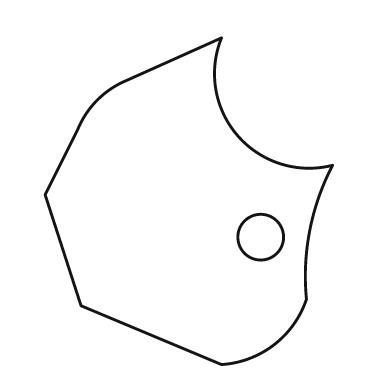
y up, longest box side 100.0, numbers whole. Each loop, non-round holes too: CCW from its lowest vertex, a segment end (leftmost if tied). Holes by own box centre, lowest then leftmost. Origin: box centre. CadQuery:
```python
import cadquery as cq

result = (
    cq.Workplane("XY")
    .moveTo(10.0, -50.0)
    .threePointArc((26.0, -44.0), (36.0, -30.0))
    .threePointArc((37.0, -9.0), (44.0, 11.0))
    .threePointArc((15.0, 20.0), (10.0, 50.0))
    .lineTo(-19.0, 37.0)
    .threePointArc((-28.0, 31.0), (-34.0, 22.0))
    .lineTo(-44.0, 2.0)
    .lineTo(-33.0, -32.0)
    .close()
    .moveTo(22.0, -11.0)
    .circle(7.0)
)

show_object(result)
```